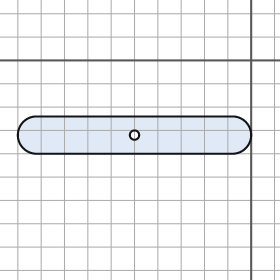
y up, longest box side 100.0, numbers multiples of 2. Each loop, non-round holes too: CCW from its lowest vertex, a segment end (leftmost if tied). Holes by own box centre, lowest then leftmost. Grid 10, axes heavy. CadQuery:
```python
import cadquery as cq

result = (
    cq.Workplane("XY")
    .moveTo(-92.0, -40.0)
    .lineTo(-8.0, -40.0)
    .threePointArc((0.0, -32.0), (-8.0, -24.0))
    .lineTo(-92.0, -24.0)
    .threePointArc((-100.0, -32.0), (-92.0, -40.0))
    .close()
    .moveTo(-50.0, -32.0)
    .circle(2.0)
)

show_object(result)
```